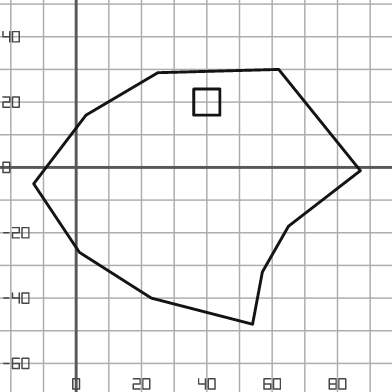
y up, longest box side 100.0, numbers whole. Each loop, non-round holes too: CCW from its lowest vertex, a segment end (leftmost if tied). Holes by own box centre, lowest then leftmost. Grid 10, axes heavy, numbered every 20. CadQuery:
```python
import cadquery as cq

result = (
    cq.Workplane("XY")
    .moveTo(54.0, -48.0)
    .lineTo(57.0, -32.0)
    .lineTo(65.0, -18.0)
    .lineTo(87.0, -1.0)
    .lineTo(62.0, 30.0)
    .lineTo(25.0, 29.0)
    .lineTo(3.0, 16.0)
    .lineTo(-13.0, -5.0)
    .lineTo(1.0, -26.0)
    .lineTo(23.0, -40.0)
    .close()
    .moveTo(36.0, 16.0)
    .lineTo(44.0, 16.0)
    .lineTo(44.0, 24.0)
    .lineTo(36.0, 24.0)
    .close()
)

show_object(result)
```